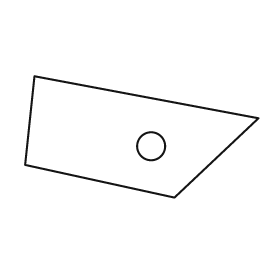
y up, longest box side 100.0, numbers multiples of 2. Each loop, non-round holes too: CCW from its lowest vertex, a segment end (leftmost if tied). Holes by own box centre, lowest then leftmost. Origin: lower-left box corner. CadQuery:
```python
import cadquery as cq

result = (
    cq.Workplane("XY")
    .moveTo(64.0, 0.0)
    .lineTo(100.0, 34.0)
    .lineTo(4.0, 52.0)
    .lineTo(0.0, 14.0)
    .close()
    .moveTo(54.0, 22.0)
    .circle(6.0)
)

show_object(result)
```